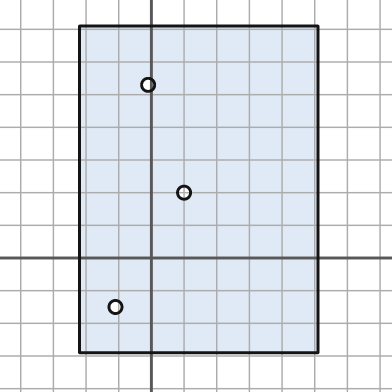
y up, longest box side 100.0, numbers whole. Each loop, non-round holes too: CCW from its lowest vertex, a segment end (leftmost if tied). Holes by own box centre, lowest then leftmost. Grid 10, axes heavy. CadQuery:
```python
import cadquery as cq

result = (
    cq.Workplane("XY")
    .moveTo(-22.0, -29.0)
    .lineTo(51.0, -29.0)
    .lineTo(51.0, 71.0)
    .lineTo(-22.0, 71.0)
    .close()
    .moveTo(-11.0, -15.0)
    .circle(2.0)
    .moveTo(10.0, 20.0)
    .circle(2.0)
    .moveTo(-1.0, 53.0)
    .circle(2.0)
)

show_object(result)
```